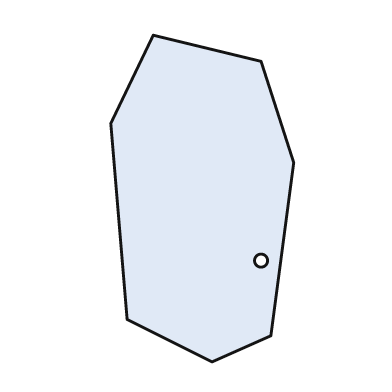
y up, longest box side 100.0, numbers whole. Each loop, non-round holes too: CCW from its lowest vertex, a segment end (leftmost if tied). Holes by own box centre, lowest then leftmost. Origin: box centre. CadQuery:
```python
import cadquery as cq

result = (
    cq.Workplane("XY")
    .moveTo(3.0, -50.0)
    .lineTo(21.0, -42.0)
    .lineTo(28.0, 11.0)
    .lineTo(18.0, 42.0)
    .lineTo(-15.0, 50.0)
    .lineTo(-28.0, 23.0)
    .lineTo(-23.0, -37.0)
    .close()
    .moveTo(18.0, -19.0)
    .circle(2.0)
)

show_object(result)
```